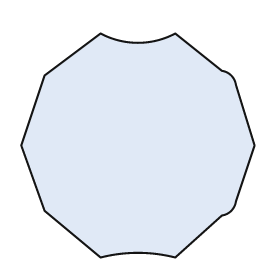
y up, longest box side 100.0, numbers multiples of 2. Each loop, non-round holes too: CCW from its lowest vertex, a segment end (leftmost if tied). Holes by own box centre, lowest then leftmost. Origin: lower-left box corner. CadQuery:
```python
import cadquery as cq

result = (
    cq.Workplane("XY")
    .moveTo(34.0, 0.0)
    .threePointArc((50.0, 2.0), (66.0, 0.0))
    .lineTo(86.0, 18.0)
    .threePointArc((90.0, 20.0), (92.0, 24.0))
    .lineTo(100.0, 48.0)
    .lineTo(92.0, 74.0)
    .threePointArc((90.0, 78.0), (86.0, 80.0))
    .lineTo(66.0, 96.0)
    .threePointArc((50.0, 92.0), (34.0, 96.0))
    .lineTo(10.0, 78.0)
    .lineTo(0.0, 48.0)
    .lineTo(10.0, 20.0)
    .close()
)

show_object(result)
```